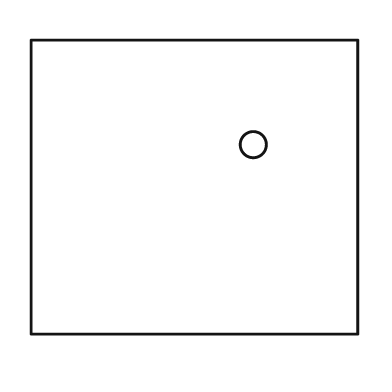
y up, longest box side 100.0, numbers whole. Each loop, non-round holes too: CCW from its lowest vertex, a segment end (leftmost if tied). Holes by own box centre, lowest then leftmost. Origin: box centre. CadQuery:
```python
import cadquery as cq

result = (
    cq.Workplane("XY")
    .moveTo(-50.0, -45.0)
    .lineTo(50.0, -45.0)
    .lineTo(50.0, 45.0)
    .lineTo(-50.0, 45.0)
    .close()
    .moveTo(18.0, 13.0)
    .circle(4.0)
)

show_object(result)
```